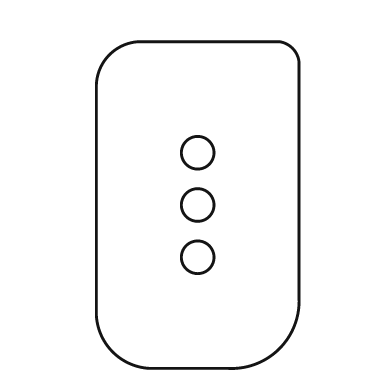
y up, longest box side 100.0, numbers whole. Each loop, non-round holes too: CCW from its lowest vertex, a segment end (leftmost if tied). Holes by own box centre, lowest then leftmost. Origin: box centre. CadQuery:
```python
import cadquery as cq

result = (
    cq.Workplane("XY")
    .moveTo(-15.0, -50.0)
    .lineTo(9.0, -50.0)
    .threePointArc((25.0, -44.0), (31.0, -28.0))
    .lineTo(31.0, 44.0)
    .threePointArc((29.0, 48.0), (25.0, 50.0))
    .lineTo(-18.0, 50.0)
    .threePointArc((-27.0, 46.0), (-31.0, 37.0))
    .lineTo(-31.0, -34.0)
    .threePointArc((-26.0, -45.0), (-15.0, -50.0))
    .close()
    .moveTo(0.0, -16.0)
    .circle(5.0)
    .moveTo(0.0, 0.0)
    .circle(5.0)
    .moveTo(0.0, 16.0)
    .circle(5.0)
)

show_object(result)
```